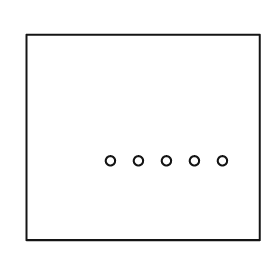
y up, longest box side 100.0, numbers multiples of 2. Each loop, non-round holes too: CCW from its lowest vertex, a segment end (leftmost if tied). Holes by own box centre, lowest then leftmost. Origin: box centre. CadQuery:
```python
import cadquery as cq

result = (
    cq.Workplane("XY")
    .moveTo(-50.0, -44.0)
    .lineTo(50.0, -44.0)
    .lineTo(50.0, 44.0)
    .lineTo(-50.0, 44.0)
    .close()
    .moveTo(-14.0, -10.0)
    .circle(2.0)
    .moveTo(-2.0, -10.0)
    .circle(2.0)
    .moveTo(10.0, -10.0)
    .circle(2.0)
    .moveTo(22.0, -10.0)
    .circle(2.0)
    .moveTo(34.0, -10.0)
    .circle(2.0)
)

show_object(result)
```